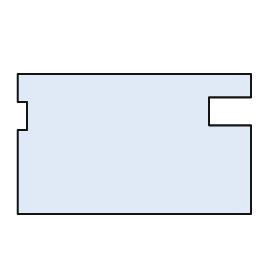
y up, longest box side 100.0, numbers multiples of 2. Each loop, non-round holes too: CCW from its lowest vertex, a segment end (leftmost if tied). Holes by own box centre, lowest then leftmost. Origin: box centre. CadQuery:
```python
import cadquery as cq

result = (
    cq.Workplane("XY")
    .moveTo(-50.0, -30.0)
    .lineTo(50.0, -30.0)
    .lineTo(50.0, 8.0)
    .lineTo(32.0, 8.0)
    .lineTo(32.0, 20.0)
    .lineTo(50.0, 20.0)
    .lineTo(50.0, 30.0)
    .lineTo(-50.0, 30.0)
    .lineTo(-50.0, 18.0)
    .lineTo(-46.0, 18.0)
    .lineTo(-46.0, 6.0)
    .lineTo(-50.0, 6.0)
    .close()
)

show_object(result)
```